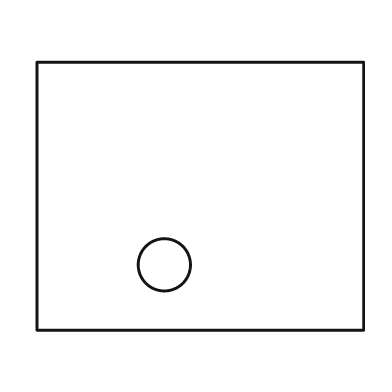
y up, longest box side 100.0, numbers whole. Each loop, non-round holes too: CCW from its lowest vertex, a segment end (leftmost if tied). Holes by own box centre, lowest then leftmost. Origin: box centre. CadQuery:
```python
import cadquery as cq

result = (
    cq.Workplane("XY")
    .moveTo(-50.0, -41.0)
    .lineTo(50.0, -41.0)
    .lineTo(50.0, 41.0)
    .lineTo(-50.0, 41.0)
    .close()
    .moveTo(-11.0, -21.0)
    .circle(8.0)
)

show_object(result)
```